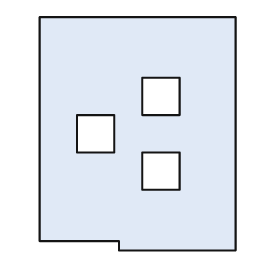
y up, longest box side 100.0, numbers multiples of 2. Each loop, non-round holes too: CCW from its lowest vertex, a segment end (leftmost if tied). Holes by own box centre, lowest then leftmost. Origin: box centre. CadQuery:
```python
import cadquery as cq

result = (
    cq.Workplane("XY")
    .moveTo(-8.0, -50.0)
    .lineTo(42.0, -50.0)
    .lineTo(42.0, 50.0)
    .lineTo(-42.0, 50.0)
    .lineTo(-42.0, -46.0)
    .lineTo(-8.0, -46.0)
    .close()
    .moveTo(2.0, -24.0)
    .lineTo(18.0, -24.0)
    .lineTo(18.0, -8.0)
    .lineTo(2.0, -8.0)
    .close()
    .moveTo(-26.0, -8.0)
    .lineTo(-10.0, -8.0)
    .lineTo(-10.0, 8.0)
    .lineTo(-26.0, 8.0)
    .close()
    .moveTo(2.0, 8.0)
    .lineTo(18.0, 8.0)
    .lineTo(18.0, 24.0)
    .lineTo(2.0, 24.0)
    .close()
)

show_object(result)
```